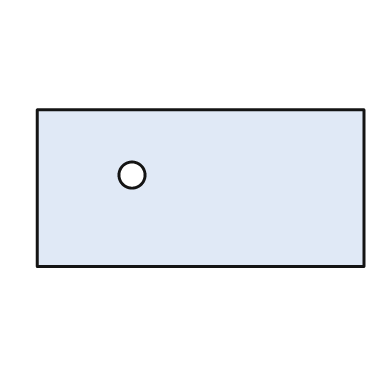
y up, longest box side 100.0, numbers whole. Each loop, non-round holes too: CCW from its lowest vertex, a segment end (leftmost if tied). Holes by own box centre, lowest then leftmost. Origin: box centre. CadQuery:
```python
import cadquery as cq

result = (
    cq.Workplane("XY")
    .moveTo(-50.0, -24.0)
    .lineTo(50.0, -24.0)
    .lineTo(50.0, 24.0)
    .lineTo(-50.0, 24.0)
    .close()
    .moveTo(-21.0, 4.0)
    .circle(4.0)
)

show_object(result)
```